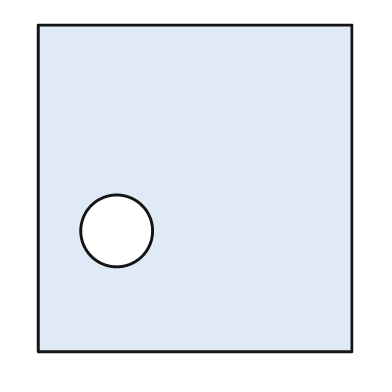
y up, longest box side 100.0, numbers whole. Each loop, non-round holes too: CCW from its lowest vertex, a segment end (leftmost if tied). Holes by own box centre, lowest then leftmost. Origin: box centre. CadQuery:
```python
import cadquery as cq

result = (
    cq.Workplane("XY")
    .moveTo(-48.0, -50.0)
    .lineTo(48.0, -50.0)
    .lineTo(48.0, 50.0)
    .lineTo(-48.0, 50.0)
    .close()
    .moveTo(-24.0, -13.0)
    .circle(11.0)
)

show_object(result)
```